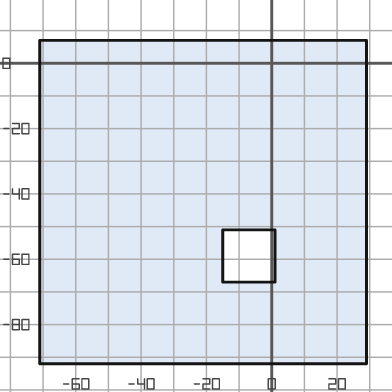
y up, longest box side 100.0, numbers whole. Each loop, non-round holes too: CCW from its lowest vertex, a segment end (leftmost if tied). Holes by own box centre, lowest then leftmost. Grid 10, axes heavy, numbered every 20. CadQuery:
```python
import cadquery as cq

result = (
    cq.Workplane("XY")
    .moveTo(-71.0, -92.0)
    .lineTo(29.0, -92.0)
    .lineTo(29.0, 7.0)
    .lineTo(-71.0, 7.0)
    .close()
    .moveTo(-15.0, -67.0)
    .lineTo(1.0, -67.0)
    .lineTo(1.0, -51.0)
    .lineTo(-15.0, -51.0)
    .close()
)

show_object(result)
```